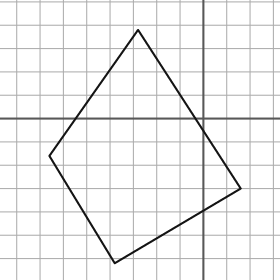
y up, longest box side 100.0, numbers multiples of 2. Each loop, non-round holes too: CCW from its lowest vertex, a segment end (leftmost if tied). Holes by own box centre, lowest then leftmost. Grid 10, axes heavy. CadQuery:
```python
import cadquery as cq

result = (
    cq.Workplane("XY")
    .moveTo(-38.0, -62.0)
    .lineTo(16.0, -30.0)
    .lineTo(-28.0, 38.0)
    .lineTo(-66.0, -16.0)
    .close()
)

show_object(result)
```